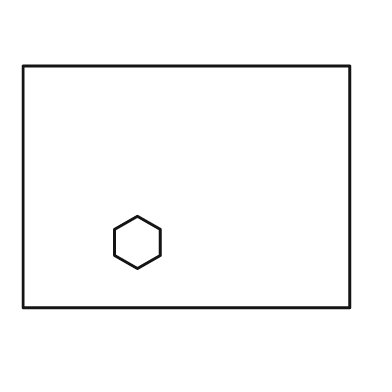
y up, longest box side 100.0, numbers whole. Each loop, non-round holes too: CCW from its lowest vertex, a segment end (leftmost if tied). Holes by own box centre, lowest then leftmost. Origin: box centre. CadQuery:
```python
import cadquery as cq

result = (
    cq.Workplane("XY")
    .moveTo(-50.0, -37.0)
    .lineTo(50.0, -37.0)
    .lineTo(50.0, 37.0)
    .lineTo(-50.0, 37.0)
    .close()
    .moveTo(-15.0, -25.0)
    .lineTo(-8.0, -21.0)
    .lineTo(-8.0, -13.0)
    .lineTo(-15.0, -9.0)
    .lineTo(-22.0, -13.0)
    .lineTo(-22.0, -21.0)
    .close()
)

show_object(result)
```